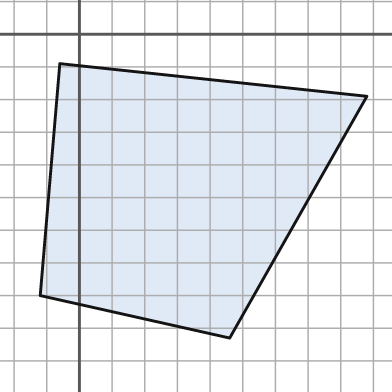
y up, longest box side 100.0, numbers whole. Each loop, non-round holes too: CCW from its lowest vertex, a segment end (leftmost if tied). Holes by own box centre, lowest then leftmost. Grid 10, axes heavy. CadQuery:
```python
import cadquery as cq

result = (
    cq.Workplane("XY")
    .moveTo(46.0, -93.0)
    .lineTo(88.0, -19.0)
    .lineTo(-6.0, -9.0)
    .lineTo(-12.0, -80.0)
    .close()
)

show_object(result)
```